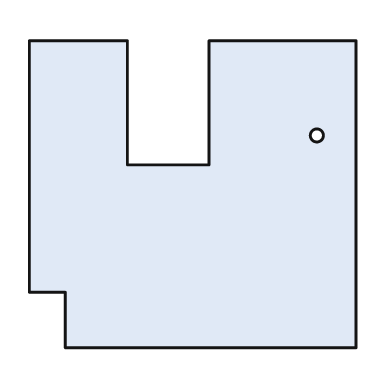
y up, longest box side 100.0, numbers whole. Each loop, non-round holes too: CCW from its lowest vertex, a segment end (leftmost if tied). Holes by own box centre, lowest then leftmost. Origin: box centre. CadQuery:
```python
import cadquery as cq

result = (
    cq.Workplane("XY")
    .moveTo(-39.0, -47.0)
    .lineTo(50.0, -47.0)
    .lineTo(50.0, 47.0)
    .lineTo(5.0, 47.0)
    .lineTo(5.0, 9.0)
    .lineTo(-20.0, 9.0)
    .lineTo(-20.0, 47.0)
    .lineTo(-50.0, 47.0)
    .lineTo(-50.0, -30.0)
    .lineTo(-39.0, -30.0)
    .close()
    .moveTo(38.0, 18.0)
    .circle(2.0)
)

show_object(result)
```